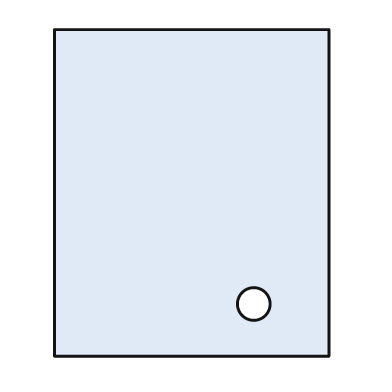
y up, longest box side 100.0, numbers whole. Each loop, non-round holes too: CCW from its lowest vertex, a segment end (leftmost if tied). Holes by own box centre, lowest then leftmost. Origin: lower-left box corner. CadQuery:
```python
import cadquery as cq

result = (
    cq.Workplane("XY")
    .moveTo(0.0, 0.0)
    .lineTo(84.0, 0.0)
    .lineTo(84.0, 100.0)
    .lineTo(0.0, 100.0)
    .close()
    .moveTo(61.0, 16.0)
    .circle(5.0)
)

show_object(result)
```